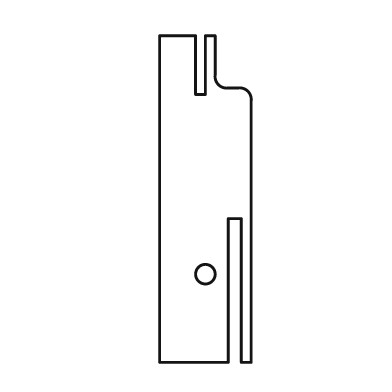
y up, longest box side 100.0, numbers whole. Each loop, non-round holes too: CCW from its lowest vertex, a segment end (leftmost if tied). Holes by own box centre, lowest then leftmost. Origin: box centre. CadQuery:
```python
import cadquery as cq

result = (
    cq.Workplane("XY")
    .moveTo(-14.0, -50.0)
    .lineTo(7.0, -50.0)
    .lineTo(7.0, -6.0)
    .lineTo(11.0, -6.0)
    .lineTo(11.0, -50.0)
    .lineTo(14.0, -50.0)
    .lineTo(14.0, 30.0)
    .threePointArc((13.0, 33.0), (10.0, 34.0))
    .lineTo(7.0, 34.0)
    .threePointArc((4.0, 35.0), (3.0, 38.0))
    .lineTo(3.0, 50.0)
    .lineTo(0.0, 50.0)
    .lineTo(0.0, 32.0)
    .lineTo(-3.0, 32.0)
    .lineTo(-3.0, 50.0)
    .lineTo(-14.0, 50.0)
    .close()
    .moveTo(0.0, -23.0)
    .circle(3.0)
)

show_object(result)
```